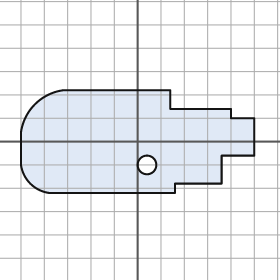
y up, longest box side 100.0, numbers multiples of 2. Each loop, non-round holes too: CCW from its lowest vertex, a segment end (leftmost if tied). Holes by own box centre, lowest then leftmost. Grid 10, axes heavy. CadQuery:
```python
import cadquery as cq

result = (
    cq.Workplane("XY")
    .moveTo(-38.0, -22.0)
    .lineTo(16.0, -22.0)
    .lineTo(16.0, -18.0)
    .lineTo(36.0, -18.0)
    .lineTo(36.0, -6.0)
    .lineTo(50.0, -6.0)
    .lineTo(50.0, 10.0)
    .lineTo(40.0, 10.0)
    .lineTo(40.0, 14.0)
    .lineTo(14.0, 14.0)
    .lineTo(14.0, 22.0)
    .lineTo(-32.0, 22.0)
    .threePointArc((-44.0, 16.0), (-50.0, 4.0))
    .lineTo(-50.0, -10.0)
    .threePointArc((-46.0, -18.0), (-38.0, -22.0))
    .close()
    .moveTo(4.0, -10.0)
    .circle(4.0)
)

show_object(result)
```